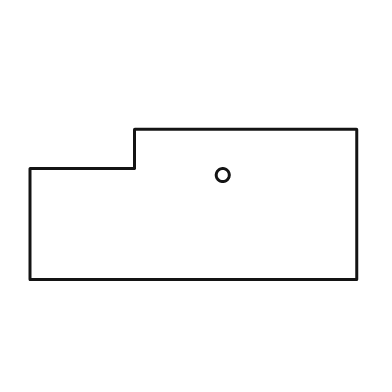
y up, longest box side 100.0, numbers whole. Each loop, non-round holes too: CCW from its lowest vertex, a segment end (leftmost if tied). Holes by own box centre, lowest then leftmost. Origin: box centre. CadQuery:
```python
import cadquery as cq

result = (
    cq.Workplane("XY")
    .moveTo(-50.0, -23.0)
    .lineTo(50.0, -23.0)
    .lineTo(50.0, 23.0)
    .lineTo(-18.0, 23.0)
    .lineTo(-18.0, 11.0)
    .lineTo(-50.0, 11.0)
    .close()
    .moveTo(9.0, 9.0)
    .circle(2.0)
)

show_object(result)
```